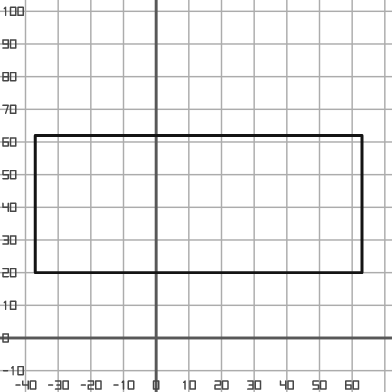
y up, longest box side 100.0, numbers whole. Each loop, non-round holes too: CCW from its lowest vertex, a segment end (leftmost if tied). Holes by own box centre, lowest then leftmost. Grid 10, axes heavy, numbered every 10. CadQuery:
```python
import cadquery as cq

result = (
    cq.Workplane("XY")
    .moveTo(-37.0, 20.0)
    .lineTo(63.0, 20.0)
    .lineTo(63.0, 62.0)
    .lineTo(-37.0, 62.0)
    .close()
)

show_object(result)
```